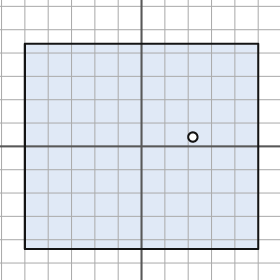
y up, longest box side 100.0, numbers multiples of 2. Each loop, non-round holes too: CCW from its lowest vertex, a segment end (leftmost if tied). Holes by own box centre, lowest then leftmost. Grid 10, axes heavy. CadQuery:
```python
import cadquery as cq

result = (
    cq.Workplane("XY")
    .moveTo(-50.0, -44.0)
    .lineTo(50.0, -44.0)
    .lineTo(50.0, 44.0)
    .lineTo(-50.0, 44.0)
    .close()
    .moveTo(22.0, 4.0)
    .circle(2.0)
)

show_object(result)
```